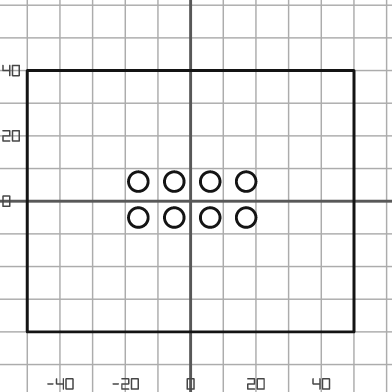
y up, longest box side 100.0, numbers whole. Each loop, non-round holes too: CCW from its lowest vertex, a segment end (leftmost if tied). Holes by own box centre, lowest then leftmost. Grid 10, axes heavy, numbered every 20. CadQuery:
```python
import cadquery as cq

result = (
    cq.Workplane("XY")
    .moveTo(-50.0, -40.0)
    .lineTo(50.0, -40.0)
    .lineTo(50.0, 40.0)
    .lineTo(-50.0, 40.0)
    .close()
    .moveTo(-16.0, -5.0)
    .circle(3.0)
    .moveTo(-5.0, -5.0)
    .circle(3.0)
    .moveTo(6.0, -5.0)
    .circle(3.0)
    .moveTo(17.0, -5.0)
    .circle(3.0)
    .moveTo(-16.0, 6.0)
    .circle(3.0)
    .moveTo(-5.0, 6.0)
    .circle(3.0)
    .moveTo(6.0, 6.0)
    .circle(3.0)
    .moveTo(17.0, 6.0)
    .circle(3.0)
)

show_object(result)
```